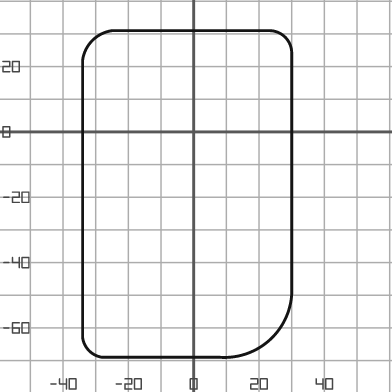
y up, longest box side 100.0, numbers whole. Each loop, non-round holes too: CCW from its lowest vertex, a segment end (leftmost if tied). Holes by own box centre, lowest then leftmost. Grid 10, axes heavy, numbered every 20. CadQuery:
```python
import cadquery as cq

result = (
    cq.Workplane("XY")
    .moveTo(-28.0, -69.0)
    .lineTo(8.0, -69.0)
    .threePointArc((24.0, -63.0), (30.0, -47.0))
    .lineTo(30.0, 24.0)
    .threePointArc((28.0, 29.0), (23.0, 31.0))
    .lineTo(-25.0, 31.0)
    .threePointArc((-31.0, 28.0), (-34.0, 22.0))
    .lineTo(-34.0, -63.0)
    .threePointArc((-32.0, -67.0), (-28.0, -69.0))
    .close()
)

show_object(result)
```